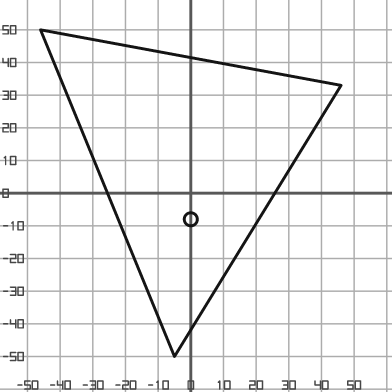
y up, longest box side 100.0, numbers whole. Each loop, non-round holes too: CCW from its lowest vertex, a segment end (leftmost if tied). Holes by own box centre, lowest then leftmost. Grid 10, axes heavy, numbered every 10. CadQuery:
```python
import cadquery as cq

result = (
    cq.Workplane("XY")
    .moveTo(-5.0, -50.0)
    .lineTo(46.0, 33.0)
    .lineTo(-46.0, 50.0)
    .close()
    .moveTo(0.0, -8.0)
    .circle(2.0)
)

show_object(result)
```